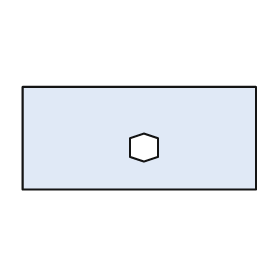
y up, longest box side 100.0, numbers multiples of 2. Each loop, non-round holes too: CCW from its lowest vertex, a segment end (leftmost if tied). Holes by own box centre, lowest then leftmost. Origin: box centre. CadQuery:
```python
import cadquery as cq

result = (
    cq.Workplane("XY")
    .moveTo(-50.0, -22.0)
    .lineTo(50.0, -22.0)
    .lineTo(50.0, 22.0)
    .lineTo(-50.0, 22.0)
    .close()
    .moveTo(2.0, -10.0)
    .lineTo(8.0, -8.0)
    .lineTo(8.0, 0.0)
    .lineTo(2.0, 2.0)
    .lineTo(-4.0, 0.0)
    .lineTo(-4.0, -8.0)
    .close()
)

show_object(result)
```